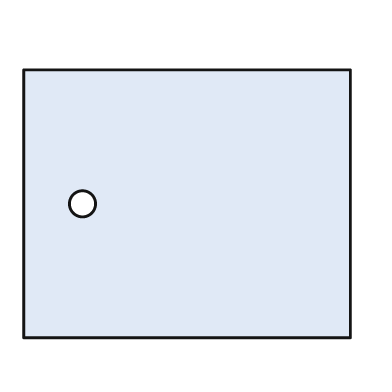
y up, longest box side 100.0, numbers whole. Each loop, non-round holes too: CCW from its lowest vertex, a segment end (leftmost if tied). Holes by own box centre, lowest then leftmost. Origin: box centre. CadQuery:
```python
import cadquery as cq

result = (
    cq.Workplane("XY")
    .moveTo(-50.0, -41.0)
    .lineTo(50.0, -41.0)
    .lineTo(50.0, 41.0)
    .lineTo(-50.0, 41.0)
    .close()
    .moveTo(-32.0, 0.0)
    .circle(4.0)
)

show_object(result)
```